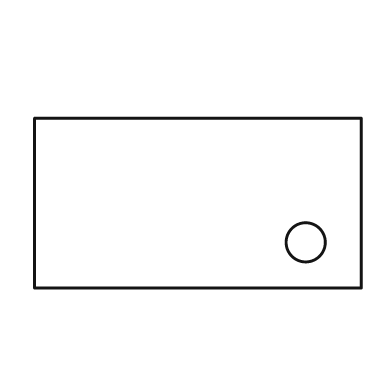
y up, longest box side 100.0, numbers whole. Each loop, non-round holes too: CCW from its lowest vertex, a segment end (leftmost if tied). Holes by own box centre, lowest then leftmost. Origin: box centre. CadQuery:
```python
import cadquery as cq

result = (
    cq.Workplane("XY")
    .moveTo(-50.0, -26.0)
    .lineTo(50.0, -26.0)
    .lineTo(50.0, 26.0)
    .lineTo(-50.0, 26.0)
    .close()
    .moveTo(33.0, -12.0)
    .circle(6.0)
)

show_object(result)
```